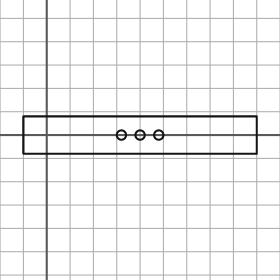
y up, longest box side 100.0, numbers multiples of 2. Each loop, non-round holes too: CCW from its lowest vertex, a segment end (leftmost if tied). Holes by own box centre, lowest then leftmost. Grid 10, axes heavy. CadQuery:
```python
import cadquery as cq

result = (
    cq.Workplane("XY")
    .moveTo(-10.0, -8.0)
    .lineTo(90.0, -8.0)
    .lineTo(90.0, 8.0)
    .lineTo(-10.0, 8.0)
    .close()
    .moveTo(32.0, 0.0)
    .circle(2.0)
    .moveTo(40.0, 0.0)
    .circle(2.0)
    .moveTo(48.0, 0.0)
    .circle(2.0)
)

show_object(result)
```